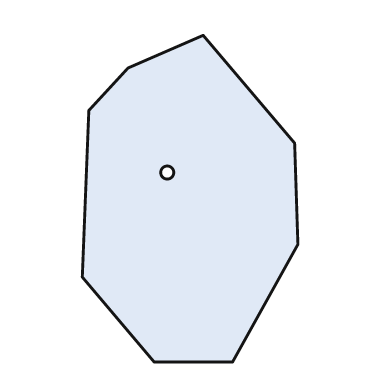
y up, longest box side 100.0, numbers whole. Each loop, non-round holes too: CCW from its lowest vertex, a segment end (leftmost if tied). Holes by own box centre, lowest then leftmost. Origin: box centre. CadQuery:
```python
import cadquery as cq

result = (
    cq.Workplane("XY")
    .moveTo(-11.0, -50.0)
    .lineTo(13.0, -50.0)
    .lineTo(33.0, -14.0)
    .lineTo(32.0, 17.0)
    .lineTo(4.0, 50.0)
    .lineTo(-19.0, 40.0)
    .lineTo(-31.0, 27.0)
    .lineTo(-33.0, -24.0)
    .close()
    .moveTo(-7.0, 8.0)
    .circle(2.0)
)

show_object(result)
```